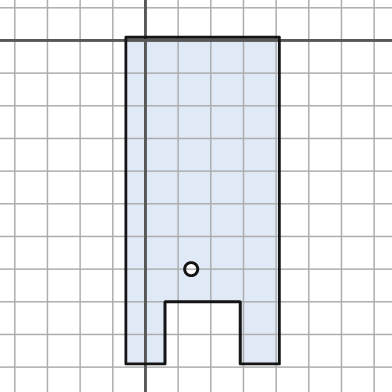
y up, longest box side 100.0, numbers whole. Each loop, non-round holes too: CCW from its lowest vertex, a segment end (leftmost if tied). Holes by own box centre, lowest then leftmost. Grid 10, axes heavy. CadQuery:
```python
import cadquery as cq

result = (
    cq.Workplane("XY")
    .moveTo(-6.0, -99.0)
    .lineTo(6.0, -99.0)
    .lineTo(6.0, -80.0)
    .lineTo(29.0, -80.0)
    .lineTo(29.0, -99.0)
    .lineTo(41.0, -99.0)
    .lineTo(41.0, 1.0)
    .lineTo(-6.0, 1.0)
    .close()
    .moveTo(14.0, -70.0)
    .circle(2.0)
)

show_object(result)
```